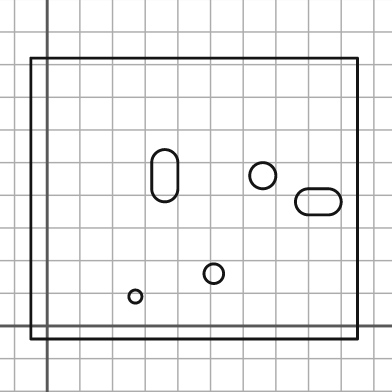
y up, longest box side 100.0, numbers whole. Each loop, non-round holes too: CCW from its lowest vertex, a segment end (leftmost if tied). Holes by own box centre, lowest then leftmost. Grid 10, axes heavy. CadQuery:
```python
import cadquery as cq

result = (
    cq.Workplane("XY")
    .moveTo(-5.0, -4.0)
    .lineTo(95.0, -4.0)
    .lineTo(95.0, 82.0)
    .lineTo(-5.0, 82.0)
    .close()
    .moveTo(27.0, 9.0)
    .circle(2.0)
    .moveTo(51.0, 16.0)
    .circle(3.0)
    .moveTo(80.0, 34.0)
    .lineTo(86.0, 34.0)
    .threePointArc((90.0, 38.0), (86.0, 42.0))
    .lineTo(80.0, 42.0)
    .threePointArc((76.0, 38.0), (80.0, 34.0))
    .close()
    .moveTo(32.0, 42.0)
    .threePointArc((36.0, 38.0), (40.0, 42.0))
    .lineTo(40.0, 50.0)
    .threePointArc((36.0, 54.0), (32.0, 50.0))
    .close()
    .moveTo(66.0, 46.0)
    .circle(4.0)
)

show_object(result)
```